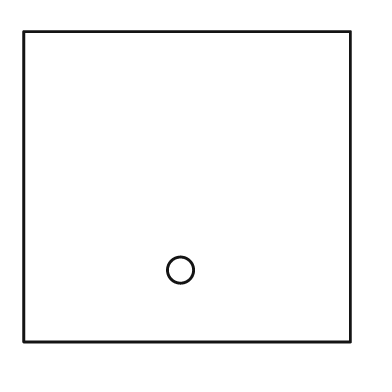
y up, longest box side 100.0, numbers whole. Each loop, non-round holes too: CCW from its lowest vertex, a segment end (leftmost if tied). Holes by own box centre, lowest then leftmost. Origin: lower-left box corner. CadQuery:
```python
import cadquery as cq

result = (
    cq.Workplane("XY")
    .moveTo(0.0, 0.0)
    .lineTo(100.0, 0.0)
    .lineTo(100.0, 95.0)
    .lineTo(0.0, 95.0)
    .close()
    .moveTo(48.0, 22.0)
    .circle(4.0)
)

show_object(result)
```